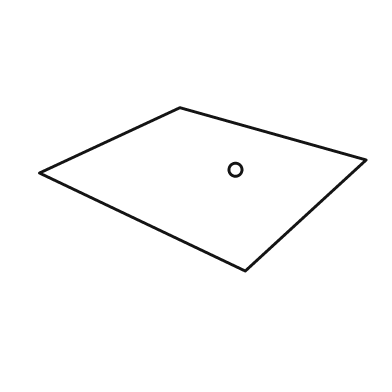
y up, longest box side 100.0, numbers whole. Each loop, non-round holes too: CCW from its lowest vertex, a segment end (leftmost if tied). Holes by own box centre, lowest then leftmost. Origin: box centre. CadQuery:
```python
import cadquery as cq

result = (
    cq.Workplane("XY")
    .moveTo(13.0, -25.0)
    .lineTo(50.0, 9.0)
    .lineTo(-7.0, 25.0)
    .lineTo(-50.0, 5.0)
    .close()
    .moveTo(10.0, 6.0)
    .circle(2.0)
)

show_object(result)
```